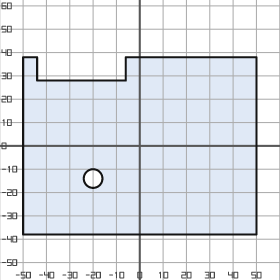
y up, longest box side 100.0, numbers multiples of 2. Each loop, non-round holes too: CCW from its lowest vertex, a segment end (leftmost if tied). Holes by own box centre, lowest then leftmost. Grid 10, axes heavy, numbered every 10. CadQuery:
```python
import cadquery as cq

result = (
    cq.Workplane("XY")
    .moveTo(-50.0, -38.0)
    .lineTo(50.0, -38.0)
    .lineTo(50.0, 38.0)
    .lineTo(-6.0, 38.0)
    .lineTo(-6.0, 28.0)
    .lineTo(-44.0, 28.0)
    .lineTo(-44.0, 38.0)
    .lineTo(-50.0, 38.0)
    .close()
    .moveTo(-20.0, -14.0)
    .circle(4.0)
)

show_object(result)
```